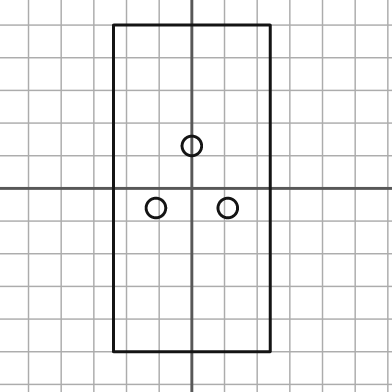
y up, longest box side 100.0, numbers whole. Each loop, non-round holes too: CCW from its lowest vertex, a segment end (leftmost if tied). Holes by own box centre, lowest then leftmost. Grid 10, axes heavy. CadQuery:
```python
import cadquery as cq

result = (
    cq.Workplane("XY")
    .moveTo(-24.0, -50.0)
    .lineTo(24.0, -50.0)
    .lineTo(24.0, 50.0)
    .lineTo(-24.0, 50.0)
    .close()
    .moveTo(-11.0, -6.0)
    .circle(3.0)
    .moveTo(11.0, -6.0)
    .circle(3.0)
    .moveTo(0.0, 13.0)
    .circle(3.0)
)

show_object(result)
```